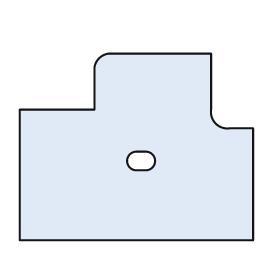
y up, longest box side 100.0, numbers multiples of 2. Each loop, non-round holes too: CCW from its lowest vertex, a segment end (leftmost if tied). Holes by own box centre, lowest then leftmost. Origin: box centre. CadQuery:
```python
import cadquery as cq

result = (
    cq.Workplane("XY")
    .moveTo(-50.0, -40.0)
    .lineTo(50.0, -40.0)
    .lineTo(50.0, 8.0)
    .lineTo(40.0, 8.0)
    .threePointArc((34.0, 10.0), (32.0, 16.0))
    .lineTo(32.0, 40.0)
    .lineTo(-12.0, 40.0)
    .threePointArc((-16.0, 38.0), (-18.0, 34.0))
    .lineTo(-18.0, 16.0)
    .lineTo(-50.0, 16.0)
    .close()
    .moveTo(0.0, -10.0)
    .lineTo(4.0, -10.0)
    .threePointArc((8.0, -6.0), (4.0, -2.0))
    .lineTo(0.0, -2.0)
    .threePointArc((-4.0, -6.0), (0.0, -10.0))
    .close()
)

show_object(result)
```